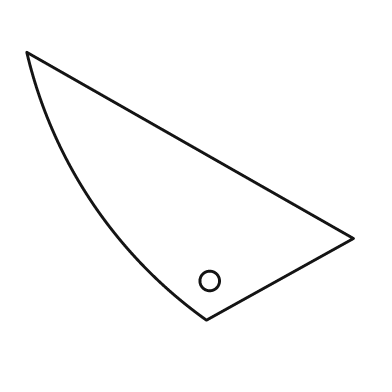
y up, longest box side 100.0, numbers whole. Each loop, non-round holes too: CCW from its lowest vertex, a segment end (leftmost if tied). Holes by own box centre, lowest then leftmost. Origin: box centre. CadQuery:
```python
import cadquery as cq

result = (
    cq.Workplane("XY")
    .moveTo(5.0, -41.0)
    .lineTo(50.0, -16.0)
    .lineTo(-50.0, 41.0)
    .threePointArc((-30.0, -5.0), (5.0, -41.0))
    .close()
    .moveTo(6.0, -29.0)
    .circle(3.0)
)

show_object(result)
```